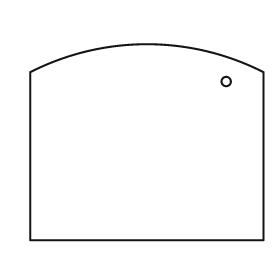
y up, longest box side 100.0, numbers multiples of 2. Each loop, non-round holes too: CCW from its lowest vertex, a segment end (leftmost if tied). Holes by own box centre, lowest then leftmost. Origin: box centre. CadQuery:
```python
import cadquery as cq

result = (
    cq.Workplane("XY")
    .moveTo(-50.0, -42.0)
    .lineTo(50.0, -42.0)
    .lineTo(50.0, 30.0)
    .threePointArc((0.0, 42.0), (-50.0, 30.0))
    .close()
    .moveTo(34.0, 26.0)
    .circle(2.0)
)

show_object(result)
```